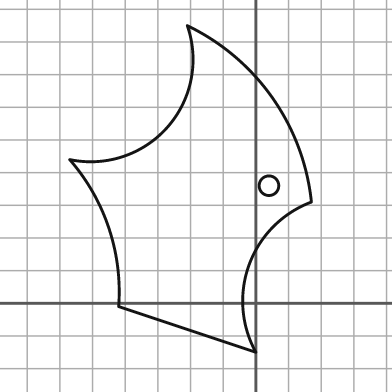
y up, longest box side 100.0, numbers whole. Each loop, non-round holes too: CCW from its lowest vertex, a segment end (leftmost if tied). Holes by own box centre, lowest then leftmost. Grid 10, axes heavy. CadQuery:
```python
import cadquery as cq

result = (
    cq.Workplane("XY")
    .moveTo(0.0, -15.0)
    .threePointArc((-2.0, 12.0), (17.0, 31.0))
    .threePointArc((5.0, 63.0), (-21.0, 85.0))
    .threePointArc((-27.0, 54.0), (-57.0, 44.0))
    .threePointArc((-45.0, 23.0), (-42.0, -1.0))
    .close()
    .moveTo(4.0, 36.0)
    .circle(3.0)
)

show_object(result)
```